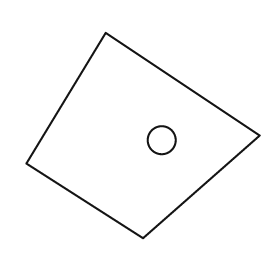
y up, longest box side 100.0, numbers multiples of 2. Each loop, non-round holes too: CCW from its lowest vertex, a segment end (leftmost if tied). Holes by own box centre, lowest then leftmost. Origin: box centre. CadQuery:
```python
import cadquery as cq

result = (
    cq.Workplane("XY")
    .moveTo(0.0, -44.0)
    .lineTo(50.0, 0.0)
    .lineTo(-16.0, 44.0)
    .lineTo(-50.0, -12.0)
    .close()
    .moveTo(8.0, -2.0)
    .circle(6.0)
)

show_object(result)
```